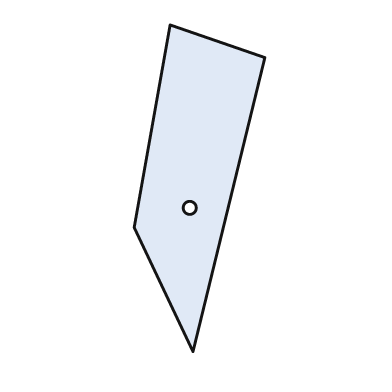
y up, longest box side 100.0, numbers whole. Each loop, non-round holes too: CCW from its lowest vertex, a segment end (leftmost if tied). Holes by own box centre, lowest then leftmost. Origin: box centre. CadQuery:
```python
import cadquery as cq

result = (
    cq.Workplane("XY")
    .moveTo(-2.0, -50.0)
    .lineTo(20.0, 40.0)
    .lineTo(-9.0, 50.0)
    .lineTo(-20.0, -12.0)
    .close()
    .moveTo(-3.0, -6.0)
    .circle(2.0)
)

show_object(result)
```